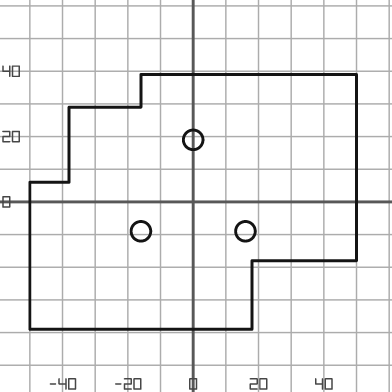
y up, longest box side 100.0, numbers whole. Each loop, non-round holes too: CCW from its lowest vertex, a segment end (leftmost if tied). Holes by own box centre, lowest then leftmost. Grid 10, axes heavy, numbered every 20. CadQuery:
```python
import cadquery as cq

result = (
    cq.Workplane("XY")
    .moveTo(-50.0, -39.0)
    .lineTo(18.0, -39.0)
    .lineTo(18.0, -18.0)
    .lineTo(50.0, -18.0)
    .lineTo(50.0, 39.0)
    .lineTo(-16.0, 39.0)
    .lineTo(-16.0, 29.0)
    .lineTo(-38.0, 29.0)
    .lineTo(-38.0, 6.0)
    .lineTo(-50.0, 6.0)
    .close()
    .moveTo(-16.0, -9.0)
    .circle(3.0)
    .moveTo(16.0, -9.0)
    .circle(3.0)
    .moveTo(0.0, 19.0)
    .circle(3.0)
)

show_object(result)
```